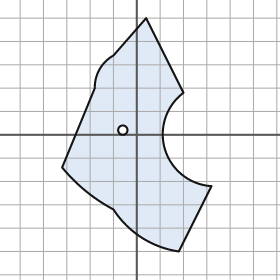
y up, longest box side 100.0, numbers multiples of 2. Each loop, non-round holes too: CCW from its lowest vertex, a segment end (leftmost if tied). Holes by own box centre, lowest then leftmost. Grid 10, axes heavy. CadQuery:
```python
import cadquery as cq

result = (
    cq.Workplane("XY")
    .moveTo(18.0, -50.0)
    .lineTo(32.0, -22.0)
    .threePointArc((12.0, -6.0), (20.0, 18.0))
    .lineTo(4.0, 50.0)
    .lineTo(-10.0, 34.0)
    .threePointArc((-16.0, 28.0), (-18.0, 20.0))
    .lineTo(-32.0, -14.0)
    .threePointArc((-22.0, -24.0), (-10.0, -32.0))
    .threePointArc((2.0, -44.0), (18.0, -50.0))
    .close()
    .moveTo(-6.0, 2.0)
    .circle(2.0)
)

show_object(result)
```